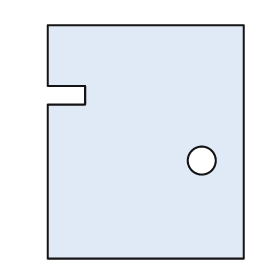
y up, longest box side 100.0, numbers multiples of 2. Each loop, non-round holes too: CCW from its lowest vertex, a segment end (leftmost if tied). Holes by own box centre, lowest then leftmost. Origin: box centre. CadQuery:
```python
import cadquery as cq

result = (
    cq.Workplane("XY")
    .moveTo(-42.0, -50.0)
    .lineTo(42.0, -50.0)
    .lineTo(42.0, 50.0)
    .lineTo(-42.0, 50.0)
    .lineTo(-42.0, 24.0)
    .lineTo(-26.0, 24.0)
    .lineTo(-26.0, 16.0)
    .lineTo(-42.0, 16.0)
    .close()
    .moveTo(24.0, -8.0)
    .circle(6.0)
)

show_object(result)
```